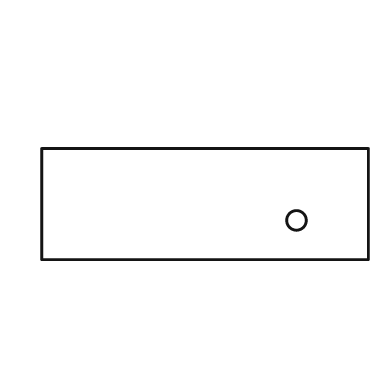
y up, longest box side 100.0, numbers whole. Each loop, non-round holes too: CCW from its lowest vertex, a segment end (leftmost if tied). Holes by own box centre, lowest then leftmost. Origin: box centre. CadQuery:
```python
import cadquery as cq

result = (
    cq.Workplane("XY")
    .moveTo(-50.0, -17.0)
    .lineTo(50.0, -17.0)
    .lineTo(50.0, 17.0)
    .lineTo(-50.0, 17.0)
    .close()
    .moveTo(28.0, -5.0)
    .circle(3.0)
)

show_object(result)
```